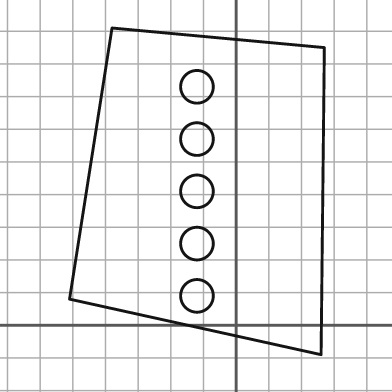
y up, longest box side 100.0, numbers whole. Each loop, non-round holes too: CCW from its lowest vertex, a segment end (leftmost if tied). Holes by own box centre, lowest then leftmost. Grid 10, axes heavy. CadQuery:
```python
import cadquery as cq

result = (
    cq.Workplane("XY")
    .moveTo(26.0, -9.0)
    .lineTo(27.0, 85.0)
    .lineTo(-38.0, 91.0)
    .lineTo(-51.0, 8.0)
    .close()
    .moveTo(-12.0, 9.0)
    .circle(5.0)
    .moveTo(-12.0, 25.0)
    .circle(5.0)
    .moveTo(-12.0, 41.0)
    .circle(5.0)
    .moveTo(-12.0, 57.0)
    .circle(5.0)
    .moveTo(-12.0, 73.0)
    .circle(5.0)
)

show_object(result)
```